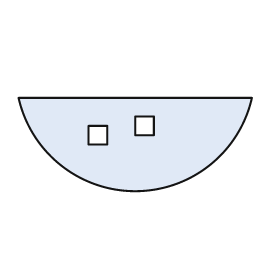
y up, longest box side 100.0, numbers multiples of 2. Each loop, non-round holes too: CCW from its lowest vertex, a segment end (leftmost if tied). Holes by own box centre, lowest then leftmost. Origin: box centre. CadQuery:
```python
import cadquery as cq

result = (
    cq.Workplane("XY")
    .moveTo(-50.0, 20.0)
    .threePointArc((0.0, -20.0), (50.0, 20.0))
    .close()
    .moveTo(-20.0, 0.0)
    .lineTo(-12.0, 0.0)
    .lineTo(-12.0, 8.0)
    .lineTo(-20.0, 8.0)
    .close()
    .moveTo(0.0, 4.0)
    .lineTo(8.0, 4.0)
    .lineTo(8.0, 12.0)
    .lineTo(0.0, 12.0)
    .close()
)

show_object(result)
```